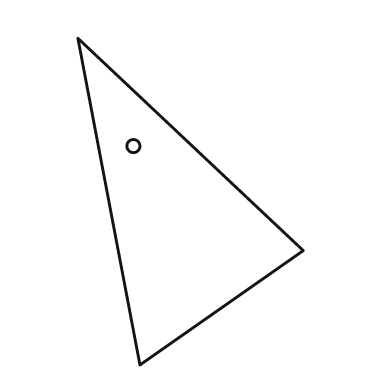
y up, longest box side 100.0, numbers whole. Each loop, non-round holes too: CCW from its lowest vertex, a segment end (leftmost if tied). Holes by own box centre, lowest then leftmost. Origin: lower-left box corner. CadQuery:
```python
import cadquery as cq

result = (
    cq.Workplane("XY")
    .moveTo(19.0, 0.0)
    .lineTo(69.0, 35.0)
    .lineTo(0.0, 100.0)
    .close()
    .moveTo(17.0, 67.0)
    .circle(2.0)
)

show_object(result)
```